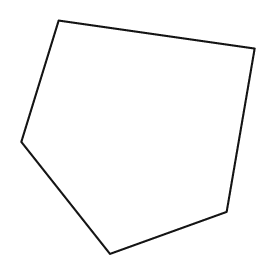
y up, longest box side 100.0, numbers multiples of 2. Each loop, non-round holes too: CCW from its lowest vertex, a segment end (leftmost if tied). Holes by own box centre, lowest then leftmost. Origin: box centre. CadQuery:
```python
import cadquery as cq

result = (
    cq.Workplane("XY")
    .moveTo(-12.0, -50.0)
    .lineTo(38.0, -32.0)
    .lineTo(50.0, 38.0)
    .lineTo(-34.0, 50.0)
    .lineTo(-50.0, -2.0)
    .close()
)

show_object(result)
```